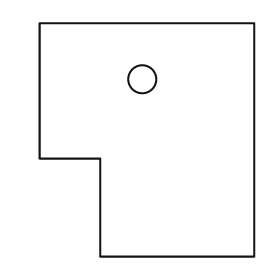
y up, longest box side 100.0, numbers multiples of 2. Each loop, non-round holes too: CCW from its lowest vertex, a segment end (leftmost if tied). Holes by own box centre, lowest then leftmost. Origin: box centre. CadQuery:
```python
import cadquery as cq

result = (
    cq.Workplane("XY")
    .moveTo(-20.0, -50.0)
    .lineTo(46.0, -50.0)
    .lineTo(46.0, 50.0)
    .lineTo(-46.0, 50.0)
    .lineTo(-46.0, -8.0)
    .lineTo(-20.0, -8.0)
    .close()
    .moveTo(-2.0, 26.0)
    .circle(6.0)
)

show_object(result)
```